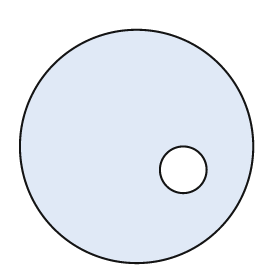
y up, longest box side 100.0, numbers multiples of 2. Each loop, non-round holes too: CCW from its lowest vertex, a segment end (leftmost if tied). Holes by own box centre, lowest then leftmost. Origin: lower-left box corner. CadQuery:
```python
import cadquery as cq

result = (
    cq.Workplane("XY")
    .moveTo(50.0, 50.0)
    .circle(50.0)
    .moveTo(70.0, 40.0)
    .circle(10.0)
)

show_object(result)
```